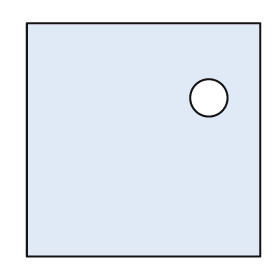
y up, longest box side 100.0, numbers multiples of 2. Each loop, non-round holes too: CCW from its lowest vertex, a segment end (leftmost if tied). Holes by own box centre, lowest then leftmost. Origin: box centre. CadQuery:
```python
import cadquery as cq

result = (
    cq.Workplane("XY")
    .moveTo(-50.0, -50.0)
    .lineTo(50.0, -50.0)
    .lineTo(50.0, 50.0)
    .lineTo(-50.0, 50.0)
    .close()
    .moveTo(28.0, 18.0)
    .circle(8.0)
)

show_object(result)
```